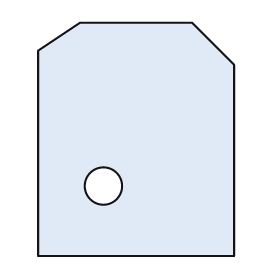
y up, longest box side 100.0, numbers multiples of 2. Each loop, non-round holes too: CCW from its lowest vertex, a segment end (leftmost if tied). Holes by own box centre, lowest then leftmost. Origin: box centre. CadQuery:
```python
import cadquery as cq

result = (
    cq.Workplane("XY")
    .moveTo(-42.0, -50.0)
    .lineTo(42.0, -50.0)
    .lineTo(42.0, 32.0)
    .lineTo(24.0, 50.0)
    .lineTo(-24.0, 50.0)
    .lineTo(-42.0, 38.0)
    .close()
    .moveTo(-14.0, -20.0)
    .circle(8.0)
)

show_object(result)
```